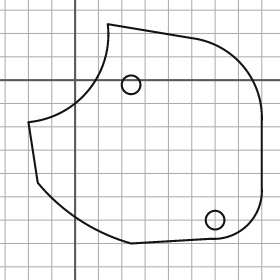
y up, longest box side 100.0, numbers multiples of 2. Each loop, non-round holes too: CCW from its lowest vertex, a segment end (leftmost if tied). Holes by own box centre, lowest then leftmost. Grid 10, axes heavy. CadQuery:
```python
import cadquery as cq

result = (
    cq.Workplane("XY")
    .moveTo(24.0, -70.0)
    .lineTo(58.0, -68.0)
    .threePointArc((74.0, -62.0), (80.0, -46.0))
    .lineTo(80.0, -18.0)
    .threePointArc((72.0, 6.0), (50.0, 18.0))
    .lineTo(14.0, 24.0)
    .threePointArc((6.0, -4.0), (-20.0, -18.0))
    .lineTo(-16.0, -44.0)
    .threePointArc((2.0, -60.0), (24.0, -70.0))
    .close()
    .moveTo(60.0, -60.0)
    .circle(4.0)
    .moveTo(24.0, -2.0)
    .circle(4.0)
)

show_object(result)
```